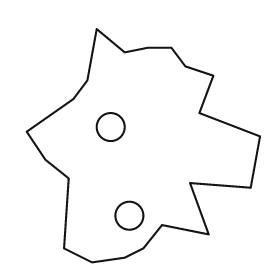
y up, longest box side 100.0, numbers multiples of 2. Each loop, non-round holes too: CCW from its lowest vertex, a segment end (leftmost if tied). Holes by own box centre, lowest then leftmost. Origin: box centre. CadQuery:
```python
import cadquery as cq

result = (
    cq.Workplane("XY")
    .moveTo(-22.0, -50.0)
    .lineTo(-8.0, -48.0)
    .lineTo(0.0, -44.0)
    .lineTo(8.0, -34.0)
    .lineTo(28.0, -38.0)
    .lineTo(20.0, -16.0)
    .lineTo(46.0, -18.0)
    .lineTo(50.0, 4.0)
    .lineTo(24.0, 14.0)
    .lineTo(30.0, 30.0)
    .lineTo(18.0, 34.0)
    .lineTo(12.0, 42.0)
    .lineTo(2.0, 42.0)
    .lineTo(-8.0, 40.0)
    .lineTo(-20.0, 50.0)
    .lineTo(-24.0, 28.0)
    .lineTo(-30.0, 20.0)
    .lineTo(-50.0, 6.0)
    .lineTo(-42.0, -6.0)
    .lineTo(-32.0, -14.0)
    .lineTo(-34.0, -44.0)
    .close()
    .moveTo(-6.0, -30.0)
    .circle(6.0)
    .moveTo(-14.0, 8.0)
    .circle(6.0)
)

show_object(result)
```